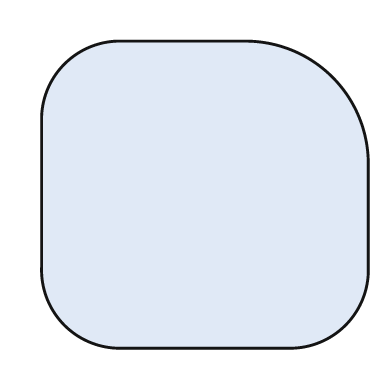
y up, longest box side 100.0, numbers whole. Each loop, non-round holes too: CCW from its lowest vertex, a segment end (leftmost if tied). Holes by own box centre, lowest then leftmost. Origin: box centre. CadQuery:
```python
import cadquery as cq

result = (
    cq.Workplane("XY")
    .moveTo(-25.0, -47.0)
    .lineTo(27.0, -47.0)
    .threePointArc((43.0, -40.0), (50.0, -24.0))
    .lineTo(50.0, 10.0)
    .threePointArc((39.0, 36.0), (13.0, 47.0))
    .lineTo(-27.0, 47.0)
    .threePointArc((-43.0, 40.0), (-50.0, 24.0))
    .lineTo(-50.0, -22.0)
    .threePointArc((-43.0, -40.0), (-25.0, -47.0))
    .close()
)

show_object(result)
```